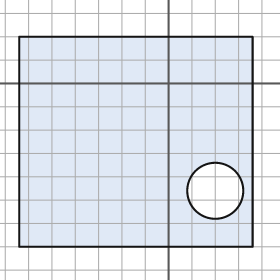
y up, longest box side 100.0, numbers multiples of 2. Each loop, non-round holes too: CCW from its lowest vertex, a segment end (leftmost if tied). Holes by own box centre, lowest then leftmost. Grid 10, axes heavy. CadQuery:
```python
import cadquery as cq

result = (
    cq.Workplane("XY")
    .moveTo(-64.0, -70.0)
    .lineTo(36.0, -70.0)
    .lineTo(36.0, 20.0)
    .lineTo(-64.0, 20.0)
    .close()
    .moveTo(20.0, -46.0)
    .circle(12.0)
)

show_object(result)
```